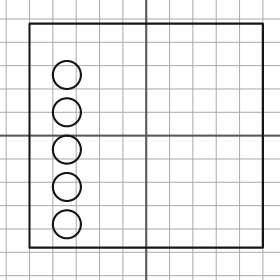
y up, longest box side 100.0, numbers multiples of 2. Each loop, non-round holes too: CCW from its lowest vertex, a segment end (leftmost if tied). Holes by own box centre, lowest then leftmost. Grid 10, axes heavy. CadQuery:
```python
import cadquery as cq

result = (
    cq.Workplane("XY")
    .moveTo(-50.0, -48.0)
    .lineTo(50.0, -48.0)
    .lineTo(50.0, 48.0)
    .lineTo(-50.0, 48.0)
    .close()
    .moveTo(-34.0, -38.0)
    .circle(6.0)
    .moveTo(-34.0, -22.0)
    .circle(6.0)
    .moveTo(-34.0, -6.0)
    .circle(6.0)
    .moveTo(-34.0, 10.0)
    .circle(6.0)
    .moveTo(-34.0, 26.0)
    .circle(6.0)
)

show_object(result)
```